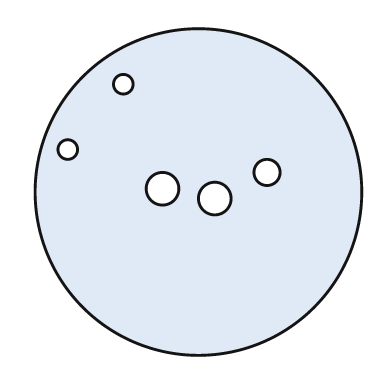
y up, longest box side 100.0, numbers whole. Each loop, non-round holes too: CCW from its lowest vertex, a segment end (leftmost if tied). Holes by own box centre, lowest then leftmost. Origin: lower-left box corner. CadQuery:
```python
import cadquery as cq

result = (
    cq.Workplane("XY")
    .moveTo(50.0, 50.0)
    .circle(50.0)
    .moveTo(55.0, 48.0)
    .circle(5.0)
    .moveTo(39.0, 51.0)
    .circle(5.0)
    .moveTo(71.0, 56.0)
    .circle(4.0)
    .moveTo(10.0, 63.0)
    .circle(3.0)
    .moveTo(27.0, 83.0)
    .circle(3.0)
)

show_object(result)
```